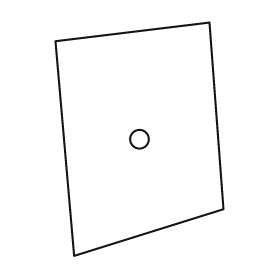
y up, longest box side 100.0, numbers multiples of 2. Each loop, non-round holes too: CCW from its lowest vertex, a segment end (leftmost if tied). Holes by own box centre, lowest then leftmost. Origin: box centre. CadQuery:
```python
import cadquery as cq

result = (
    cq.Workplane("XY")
    .moveTo(-28.0, -50.0)
    .lineTo(36.0, -30.0)
    .lineTo(30.0, 50.0)
    .lineTo(-36.0, 42.0)
    .close()
    .moveTo(0.0, 0.0)
    .circle(4.0)
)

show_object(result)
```